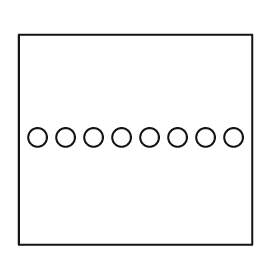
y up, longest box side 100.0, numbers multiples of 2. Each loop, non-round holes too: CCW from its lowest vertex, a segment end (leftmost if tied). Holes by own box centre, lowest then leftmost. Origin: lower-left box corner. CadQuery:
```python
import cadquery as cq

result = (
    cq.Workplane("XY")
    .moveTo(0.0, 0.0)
    .lineTo(100.0, 0.0)
    .lineTo(100.0, 90.0)
    .lineTo(0.0, 90.0)
    .close()
    .moveTo(8.0, 46.0)
    .circle(4.0)
    .moveTo(20.0, 46.0)
    .circle(4.0)
    .moveTo(32.0, 46.0)
    .circle(4.0)
    .moveTo(44.0, 46.0)
    .circle(4.0)
    .moveTo(56.0, 46.0)
    .circle(4.0)
    .moveTo(68.0, 46.0)
    .circle(4.0)
    .moveTo(80.0, 46.0)
    .circle(4.0)
    .moveTo(92.0, 46.0)
    .circle(4.0)
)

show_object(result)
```